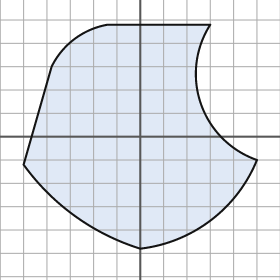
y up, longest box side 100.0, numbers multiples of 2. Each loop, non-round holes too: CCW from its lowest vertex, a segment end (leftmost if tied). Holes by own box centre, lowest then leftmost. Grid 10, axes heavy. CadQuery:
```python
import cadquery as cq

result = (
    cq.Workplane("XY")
    .moveTo(0.0, -48.0)
    .threePointArc((30.0, -36.0), (50.0, -10.0))
    .threePointArc((26.0, 14.0), (30.0, 48.0))
    .lineTo(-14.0, 48.0)
    .threePointArc((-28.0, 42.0), (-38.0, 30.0))
    .lineTo(-50.0, -12.0)
    .threePointArc((-28.0, -34.0), (0.0, -48.0))
    .close()
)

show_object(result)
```